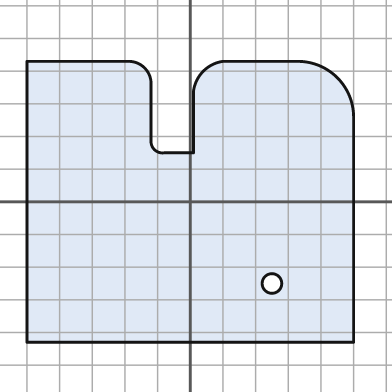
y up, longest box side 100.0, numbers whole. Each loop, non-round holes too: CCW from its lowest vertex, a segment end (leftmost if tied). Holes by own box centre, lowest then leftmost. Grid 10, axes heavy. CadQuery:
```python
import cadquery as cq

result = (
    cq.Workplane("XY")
    .moveTo(-50.0, -43.0)
    .lineTo(50.0, -43.0)
    .lineTo(50.0, 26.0)
    .threePointArc((45.0, 38.0), (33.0, 43.0))
    .lineTo(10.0, 43.0)
    .threePointArc((4.0, 40.0), (1.0, 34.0))
    .lineTo(1.0, 15.0)
    .lineTo(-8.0, 15.0)
    .threePointArc((-11.0, 16.0), (-12.0, 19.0))
    .lineTo(-12.0, 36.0)
    .threePointArc((-14.0, 41.0), (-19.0, 43.0))
    .lineTo(-50.0, 43.0)
    .close()
    .moveTo(25.0, -25.0)
    .circle(3.0)
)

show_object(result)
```